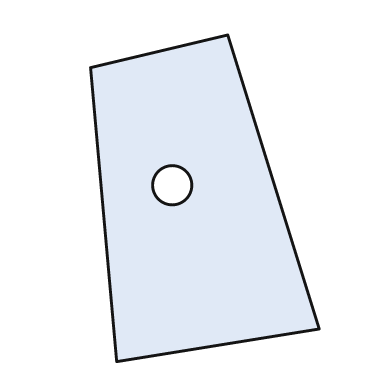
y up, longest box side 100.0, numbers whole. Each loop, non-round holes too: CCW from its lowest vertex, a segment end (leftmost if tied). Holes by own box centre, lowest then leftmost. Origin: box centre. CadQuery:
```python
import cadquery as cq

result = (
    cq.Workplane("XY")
    .moveTo(-27.0, -50.0)
    .lineTo(35.0, -40.0)
    .lineTo(7.0, 50.0)
    .lineTo(-35.0, 40.0)
    .close()
    .moveTo(-10.0, 4.0)
    .circle(6.0)
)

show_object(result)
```